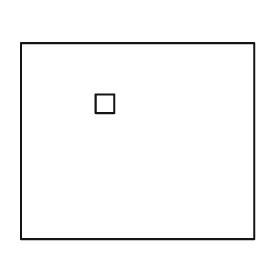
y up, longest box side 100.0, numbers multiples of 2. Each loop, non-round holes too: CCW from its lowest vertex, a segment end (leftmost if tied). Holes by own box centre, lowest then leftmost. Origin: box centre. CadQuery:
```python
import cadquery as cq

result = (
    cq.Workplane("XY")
    .moveTo(-50.0, -42.0)
    .lineTo(50.0, -42.0)
    .lineTo(50.0, 42.0)
    .lineTo(-50.0, 42.0)
    .close()
    .moveTo(-18.0, 12.0)
    .lineTo(-10.0, 12.0)
    .lineTo(-10.0, 20.0)
    .lineTo(-18.0, 20.0)
    .close()
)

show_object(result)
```